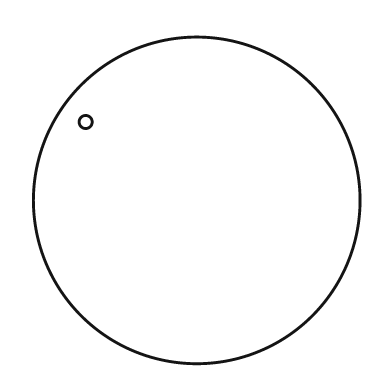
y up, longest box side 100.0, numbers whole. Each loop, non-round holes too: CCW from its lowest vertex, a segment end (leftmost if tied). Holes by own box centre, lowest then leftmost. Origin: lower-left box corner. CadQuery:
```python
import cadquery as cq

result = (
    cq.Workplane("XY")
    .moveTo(50.0, 50.0)
    .circle(50.0)
    .moveTo(16.0, 74.0)
    .circle(2.0)
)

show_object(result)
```